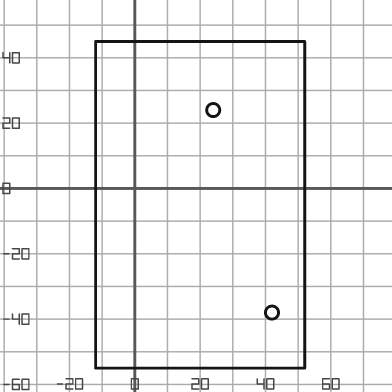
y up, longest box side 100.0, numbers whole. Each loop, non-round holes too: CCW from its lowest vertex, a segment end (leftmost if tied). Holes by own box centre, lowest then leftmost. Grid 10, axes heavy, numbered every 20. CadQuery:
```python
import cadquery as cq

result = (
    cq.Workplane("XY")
    .moveTo(-12.0, -55.0)
    .lineTo(52.0, -55.0)
    .lineTo(52.0, 45.0)
    .lineTo(-12.0, 45.0)
    .close()
    .moveTo(42.0, -38.0)
    .circle(2.0)
    .moveTo(24.0, 24.0)
    .circle(2.0)
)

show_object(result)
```